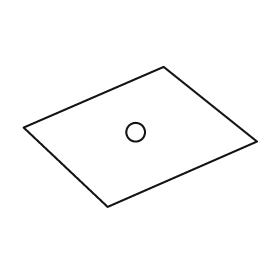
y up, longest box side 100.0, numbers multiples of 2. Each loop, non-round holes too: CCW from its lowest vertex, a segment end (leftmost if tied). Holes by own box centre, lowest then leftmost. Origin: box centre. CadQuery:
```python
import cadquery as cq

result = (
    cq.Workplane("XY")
    .moveTo(-14.0, -30.0)
    .lineTo(50.0, -2.0)
    .lineTo(10.0, 30.0)
    .lineTo(-50.0, 4.0)
    .close()
    .moveTo(-2.0, 2.0)
    .circle(4.0)
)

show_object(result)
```